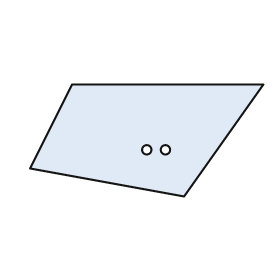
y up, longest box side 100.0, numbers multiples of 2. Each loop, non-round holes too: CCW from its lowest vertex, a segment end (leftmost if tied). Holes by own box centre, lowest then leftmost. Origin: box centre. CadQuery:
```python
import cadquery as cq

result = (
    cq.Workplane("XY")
    .moveTo(16.0, -24.0)
    .lineTo(50.0, 24.0)
    .lineTo(-32.0, 24.0)
    .lineTo(-50.0, -12.0)
    .close()
    .moveTo(0.0, -4.0)
    .circle(2.0)
    .moveTo(8.0, -4.0)
    .circle(2.0)
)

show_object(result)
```